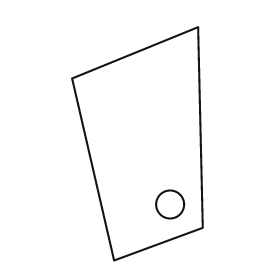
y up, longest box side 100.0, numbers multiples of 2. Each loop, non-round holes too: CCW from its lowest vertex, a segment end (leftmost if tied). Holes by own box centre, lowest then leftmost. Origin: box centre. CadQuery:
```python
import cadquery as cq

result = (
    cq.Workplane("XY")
    .moveTo(-10.0, -50.0)
    .lineTo(28.0, -36.0)
    .lineTo(26.0, 50.0)
    .lineTo(-28.0, 28.0)
    .close()
    .moveTo(14.0, -26.0)
    .circle(6.0)
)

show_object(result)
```